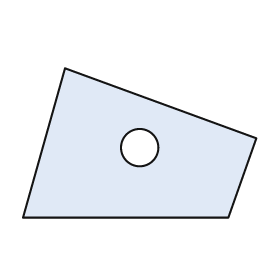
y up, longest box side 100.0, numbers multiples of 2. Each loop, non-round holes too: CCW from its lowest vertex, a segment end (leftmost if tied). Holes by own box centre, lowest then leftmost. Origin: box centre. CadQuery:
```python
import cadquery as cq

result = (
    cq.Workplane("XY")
    .moveTo(-50.0, -32.0)
    .lineTo(38.0, -32.0)
    .lineTo(50.0, 2.0)
    .lineTo(-32.0, 32.0)
    .close()
    .moveTo(0.0, -2.0)
    .circle(8.0)
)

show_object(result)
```